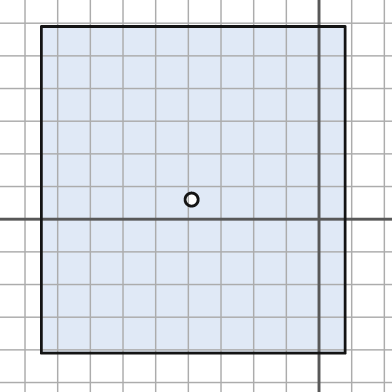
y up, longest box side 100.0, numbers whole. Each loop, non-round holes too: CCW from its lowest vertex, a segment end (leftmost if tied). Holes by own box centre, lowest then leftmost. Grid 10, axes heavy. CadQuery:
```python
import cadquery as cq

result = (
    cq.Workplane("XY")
    .moveTo(-85.0, -41.0)
    .lineTo(8.0, -41.0)
    .lineTo(8.0, 59.0)
    .lineTo(-85.0, 59.0)
    .close()
    .moveTo(-39.0, 6.0)
    .circle(2.0)
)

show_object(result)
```